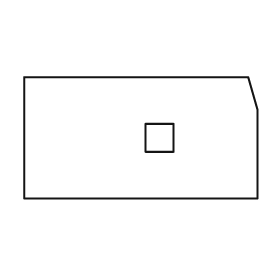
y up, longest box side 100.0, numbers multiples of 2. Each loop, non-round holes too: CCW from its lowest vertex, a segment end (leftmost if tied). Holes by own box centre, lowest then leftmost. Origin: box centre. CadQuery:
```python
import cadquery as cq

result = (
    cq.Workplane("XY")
    .moveTo(-50.0, -26.0)
    .lineTo(50.0, -26.0)
    .lineTo(50.0, 12.0)
    .lineTo(46.0, 26.0)
    .lineTo(-50.0, 26.0)
    .close()
    .moveTo(2.0, -6.0)
    .lineTo(14.0, -6.0)
    .lineTo(14.0, 6.0)
    .lineTo(2.0, 6.0)
    .close()
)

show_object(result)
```